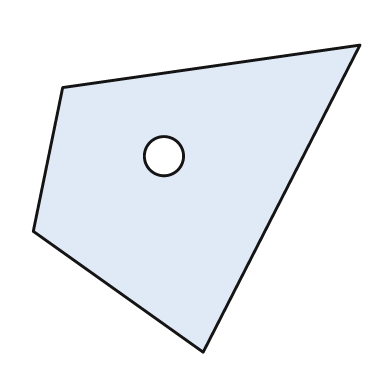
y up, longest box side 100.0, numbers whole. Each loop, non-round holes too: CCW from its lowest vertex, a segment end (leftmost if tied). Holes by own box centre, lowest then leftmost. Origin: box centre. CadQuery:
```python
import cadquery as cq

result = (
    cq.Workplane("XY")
    .moveTo(2.0, -47.0)
    .lineTo(50.0, 47.0)
    .lineTo(-41.0, 34.0)
    .lineTo(-50.0, -10.0)
    .close()
    .moveTo(-10.0, 13.0)
    .circle(6.0)
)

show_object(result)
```